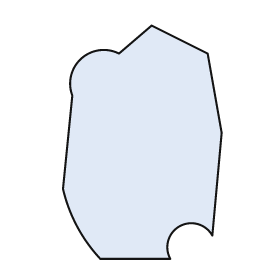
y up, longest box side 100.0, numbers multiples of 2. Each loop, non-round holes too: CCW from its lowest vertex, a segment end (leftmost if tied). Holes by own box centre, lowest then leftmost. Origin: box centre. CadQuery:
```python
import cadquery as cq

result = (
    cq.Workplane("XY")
    .moveTo(-18.0, -50.0)
    .lineTo(12.0, -50.0)
    .threePointArc((16.0, -36.0), (30.0, -40.0))
    .lineTo(34.0, 4.0)
    .lineTo(28.0, 38.0)
    .lineTo(4.0, 50.0)
    .lineTo(-10.0, 38.0)
    .threePointArc((-26.0, 36.0), (-30.0, 20.0))
    .lineTo(-34.0, -20.0)
    .threePointArc((-28.0, -36.0), (-18.0, -50.0))
    .close()
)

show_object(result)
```